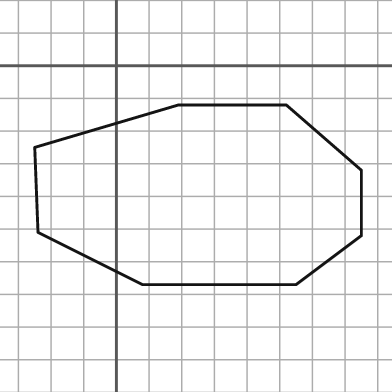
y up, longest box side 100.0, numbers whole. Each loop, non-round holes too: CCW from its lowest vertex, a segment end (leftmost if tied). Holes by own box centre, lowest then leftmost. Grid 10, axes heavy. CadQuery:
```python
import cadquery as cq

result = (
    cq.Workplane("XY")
    .moveTo(8.0, -67.0)
    .lineTo(55.0, -67.0)
    .lineTo(75.0, -52.0)
    .lineTo(75.0, -32.0)
    .lineTo(52.0, -12.0)
    .lineTo(19.0, -12.0)
    .lineTo(-25.0, -25.0)
    .lineTo(-24.0, -51.0)
    .close()
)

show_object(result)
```